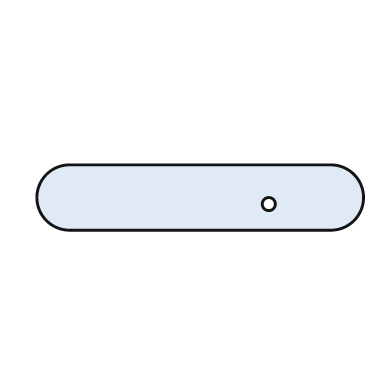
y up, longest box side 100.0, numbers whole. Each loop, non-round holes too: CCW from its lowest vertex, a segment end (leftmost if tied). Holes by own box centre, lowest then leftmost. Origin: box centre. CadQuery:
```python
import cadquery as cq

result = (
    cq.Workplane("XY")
    .moveTo(-40.0, -10.0)
    .lineTo(40.0, -10.0)
    .threePointArc((50.0, 0.0), (40.0, 10.0))
    .lineTo(-40.0, 10.0)
    .threePointArc((-50.0, 0.0), (-40.0, -10.0))
    .close()
    .moveTo(21.0, -2.0)
    .circle(2.0)
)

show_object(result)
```